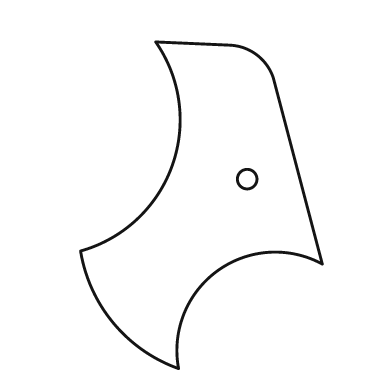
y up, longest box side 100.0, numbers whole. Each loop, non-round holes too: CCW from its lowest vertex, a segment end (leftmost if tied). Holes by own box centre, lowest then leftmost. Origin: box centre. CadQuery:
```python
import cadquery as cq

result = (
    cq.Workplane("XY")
    .moveTo(-7.0, -50.0)
    .threePointArc((5.0, -20.0), (37.0, -18.0))
    .lineTo(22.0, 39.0)
    .threePointArc((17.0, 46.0), (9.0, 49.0))
    .lineTo(-14.0, 50.0)
    .threePointArc((-9.0, 12.0), (-37.0, -14.0))
    .threePointArc((-27.0, -36.0), (-7.0, -50.0))
    .close()
    .moveTo(14.0, 8.0)
    .circle(3.0)
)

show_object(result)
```